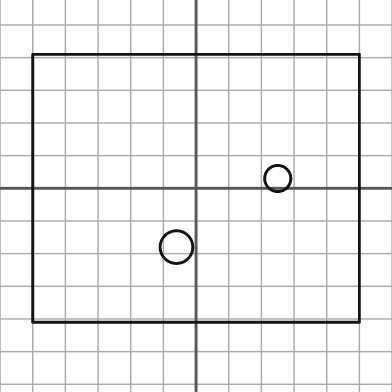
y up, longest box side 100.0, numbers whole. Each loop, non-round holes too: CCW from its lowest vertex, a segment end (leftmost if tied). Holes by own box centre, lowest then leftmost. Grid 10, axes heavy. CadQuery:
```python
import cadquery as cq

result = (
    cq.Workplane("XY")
    .moveTo(-50.0, -41.0)
    .lineTo(50.0, -41.0)
    .lineTo(50.0, 41.0)
    .lineTo(-50.0, 41.0)
    .close()
    .moveTo(-6.0, -18.0)
    .circle(5.0)
    .moveTo(25.0, 3.0)
    .circle(4.0)
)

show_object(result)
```